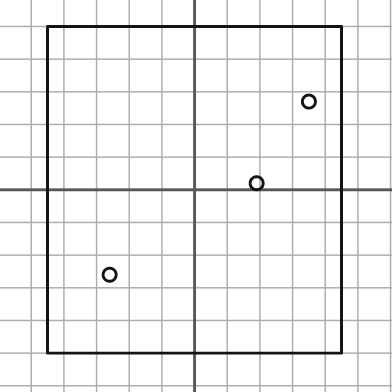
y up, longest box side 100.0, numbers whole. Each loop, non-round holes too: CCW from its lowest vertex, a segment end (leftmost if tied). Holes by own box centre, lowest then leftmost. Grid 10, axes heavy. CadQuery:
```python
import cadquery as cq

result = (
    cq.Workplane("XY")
    .moveTo(-45.0, -50.0)
    .lineTo(45.0, -50.0)
    .lineTo(45.0, 50.0)
    .lineTo(-45.0, 50.0)
    .close()
    .moveTo(-26.0, -26.0)
    .circle(2.0)
    .moveTo(19.0, 2.0)
    .circle(2.0)
    .moveTo(35.0, 27.0)
    .circle(2.0)
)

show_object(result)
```